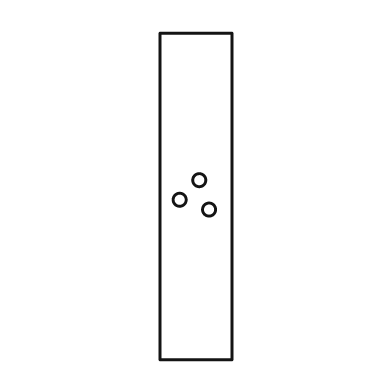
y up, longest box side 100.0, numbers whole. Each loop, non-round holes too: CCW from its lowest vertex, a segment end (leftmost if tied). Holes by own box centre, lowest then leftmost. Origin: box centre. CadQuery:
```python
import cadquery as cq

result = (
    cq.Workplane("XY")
    .moveTo(-11.0, -50.0)
    .lineTo(11.0, -50.0)
    .lineTo(11.0, 50.0)
    .lineTo(-11.0, 50.0)
    .close()
    .moveTo(4.0, -4.0)
    .circle(2.0)
    .moveTo(-5.0, -1.0)
    .circle(2.0)
    .moveTo(1.0, 5.0)
    .circle(2.0)
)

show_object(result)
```